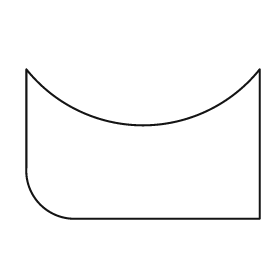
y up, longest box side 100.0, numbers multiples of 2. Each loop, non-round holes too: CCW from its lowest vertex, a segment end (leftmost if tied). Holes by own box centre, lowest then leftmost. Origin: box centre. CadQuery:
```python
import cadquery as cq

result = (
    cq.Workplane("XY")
    .moveTo(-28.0, -32.0)
    .lineTo(50.0, -32.0)
    .lineTo(50.0, 32.0)
    .threePointArc((0.0, 8.0), (-50.0, 32.0))
    .lineTo(-50.0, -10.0)
    .threePointArc((-44.0, -26.0), (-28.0, -32.0))
    .close()
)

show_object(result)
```